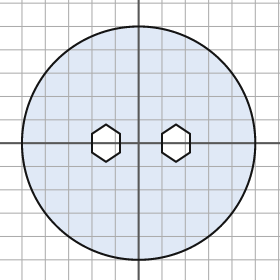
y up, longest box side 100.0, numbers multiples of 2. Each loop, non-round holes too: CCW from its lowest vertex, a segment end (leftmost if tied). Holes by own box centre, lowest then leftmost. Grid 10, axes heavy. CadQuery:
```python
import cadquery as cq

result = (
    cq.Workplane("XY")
    .moveTo(0.0, 0.0)
    .circle(50.0)
    .moveTo(-14.0, -8.0)
    .lineTo(-8.0, -4.0)
    .lineTo(-8.0, 4.0)
    .lineTo(-14.0, 8.0)
    .lineTo(-20.0, 4.0)
    .lineTo(-20.0, -4.0)
    .close()
    .moveTo(16.0, -8.0)
    .lineTo(22.0, -4.0)
    .lineTo(22.0, 4.0)
    .lineTo(16.0, 8.0)
    .lineTo(10.0, 4.0)
    .lineTo(10.0, -4.0)
    .close()
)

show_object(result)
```